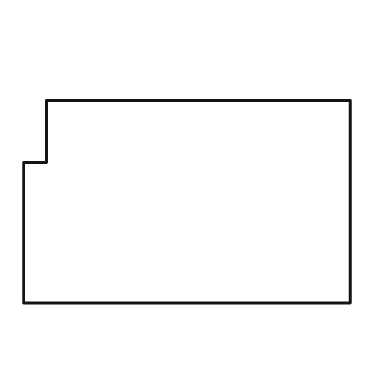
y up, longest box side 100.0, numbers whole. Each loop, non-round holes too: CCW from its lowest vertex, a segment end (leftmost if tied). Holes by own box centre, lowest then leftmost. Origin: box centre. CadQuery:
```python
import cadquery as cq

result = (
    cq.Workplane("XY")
    .moveTo(-50.0, -31.0)
    .lineTo(50.0, -31.0)
    .lineTo(50.0, 31.0)
    .lineTo(-43.0, 31.0)
    .lineTo(-43.0, 12.0)
    .lineTo(-50.0, 12.0)
    .close()
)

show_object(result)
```